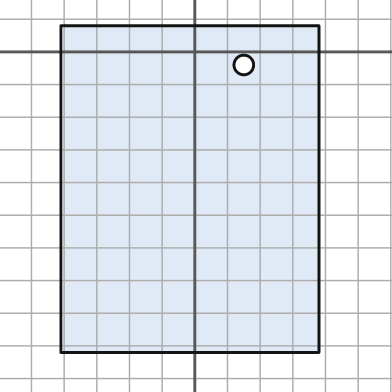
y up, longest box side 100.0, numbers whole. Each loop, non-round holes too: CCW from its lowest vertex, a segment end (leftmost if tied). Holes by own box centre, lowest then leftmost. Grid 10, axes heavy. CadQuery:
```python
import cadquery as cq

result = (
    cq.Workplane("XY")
    .moveTo(-41.0, -92.0)
    .lineTo(38.0, -92.0)
    .lineTo(38.0, 8.0)
    .lineTo(-41.0, 8.0)
    .close()
    .moveTo(15.0, -4.0)
    .circle(3.0)
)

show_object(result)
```